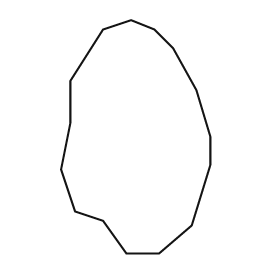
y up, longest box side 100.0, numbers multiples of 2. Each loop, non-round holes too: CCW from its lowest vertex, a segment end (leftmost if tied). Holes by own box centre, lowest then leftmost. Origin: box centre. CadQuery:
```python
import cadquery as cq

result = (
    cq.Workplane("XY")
    .moveTo(-4.0, -50.0)
    .lineTo(10.0, -50.0)
    .lineTo(24.0, -38.0)
    .lineTo(32.0, -12.0)
    .lineTo(32.0, 0.0)
    .lineTo(26.0, 20.0)
    .lineTo(16.0, 38.0)
    .lineTo(8.0, 46.0)
    .lineTo(-2.0, 50.0)
    .lineTo(-14.0, 46.0)
    .lineTo(-28.0, 24.0)
    .lineTo(-28.0, 6.0)
    .lineTo(-32.0, -14.0)
    .lineTo(-26.0, -32.0)
    .lineTo(-14.0, -36.0)
    .close()
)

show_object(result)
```